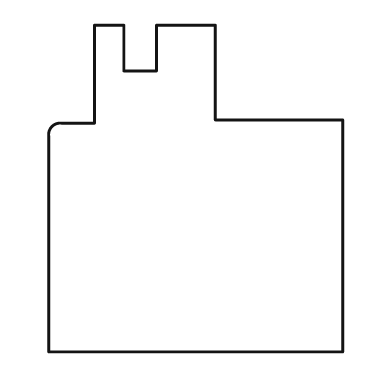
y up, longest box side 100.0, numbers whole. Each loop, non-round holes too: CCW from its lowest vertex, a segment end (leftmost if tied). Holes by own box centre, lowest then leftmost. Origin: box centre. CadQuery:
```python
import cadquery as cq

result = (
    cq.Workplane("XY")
    .moveTo(-45.0, -50.0)
    .lineTo(45.0, -50.0)
    .lineTo(45.0, 21.0)
    .lineTo(6.0, 21.0)
    .lineTo(6.0, 50.0)
    .lineTo(-12.0, 50.0)
    .lineTo(-12.0, 36.0)
    .lineTo(-22.0, 36.0)
    .lineTo(-22.0, 50.0)
    .lineTo(-31.0, 50.0)
    .lineTo(-31.0, 20.0)
    .lineTo(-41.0, 20.0)
    .threePointArc((-44.0, 19.0), (-45.0, 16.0))
    .close()
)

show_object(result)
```